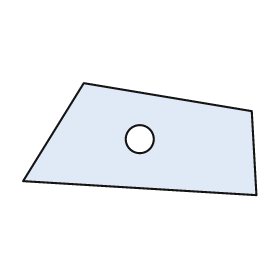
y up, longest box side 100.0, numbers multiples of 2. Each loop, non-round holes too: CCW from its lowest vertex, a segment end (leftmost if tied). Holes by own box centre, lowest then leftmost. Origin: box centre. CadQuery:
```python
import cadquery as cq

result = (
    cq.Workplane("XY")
    .moveTo(50.0, -24.0)
    .lineTo(48.0, 12.0)
    .lineTo(-24.0, 24.0)
    .lineTo(-50.0, -18.0)
    .close()
    .moveTo(0.0, 0.0)
    .circle(6.0)
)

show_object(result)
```